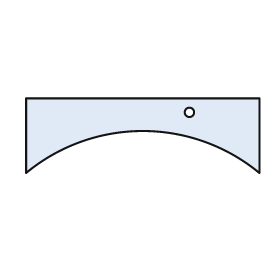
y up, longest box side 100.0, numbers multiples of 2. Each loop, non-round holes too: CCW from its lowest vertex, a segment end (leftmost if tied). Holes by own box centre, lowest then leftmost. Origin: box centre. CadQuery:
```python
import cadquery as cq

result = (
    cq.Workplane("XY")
    .moveTo(-50.0, -16.0)
    .threePointArc((0.0, 2.0), (50.0, -16.0))
    .lineTo(50.0, 16.0)
    .lineTo(-50.0, 16.0)
    .close()
    .moveTo(20.0, 10.0)
    .circle(2.0)
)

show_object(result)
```